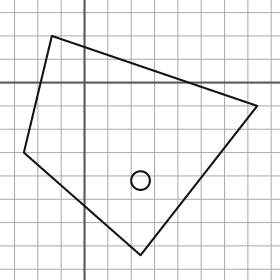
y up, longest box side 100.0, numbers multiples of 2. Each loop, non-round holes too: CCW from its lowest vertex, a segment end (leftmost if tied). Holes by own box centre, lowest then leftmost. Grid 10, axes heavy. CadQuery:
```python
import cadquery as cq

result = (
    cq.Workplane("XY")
    .moveTo(24.0, -74.0)
    .lineTo(74.0, -10.0)
    .lineTo(-14.0, 20.0)
    .lineTo(-26.0, -30.0)
    .close()
    .moveTo(24.0, -42.0)
    .circle(4.0)
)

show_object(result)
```